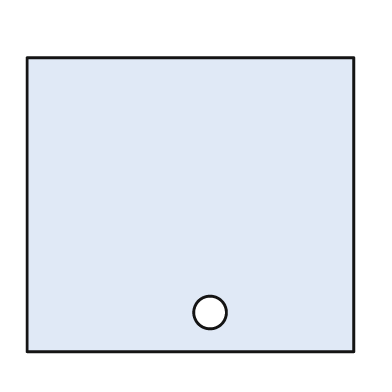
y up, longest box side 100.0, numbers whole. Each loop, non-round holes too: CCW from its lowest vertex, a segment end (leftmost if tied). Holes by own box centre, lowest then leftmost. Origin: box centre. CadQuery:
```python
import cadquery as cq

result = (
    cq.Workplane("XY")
    .moveTo(-50.0, -45.0)
    .lineTo(50.0, -45.0)
    .lineTo(50.0, 45.0)
    .lineTo(-50.0, 45.0)
    .close()
    .moveTo(6.0, -33.0)
    .circle(5.0)
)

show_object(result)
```